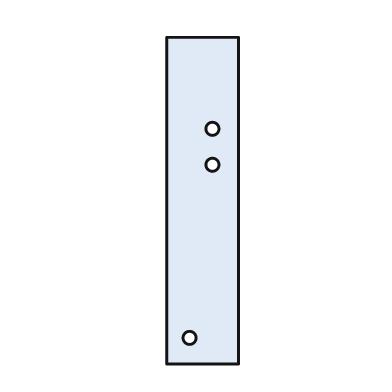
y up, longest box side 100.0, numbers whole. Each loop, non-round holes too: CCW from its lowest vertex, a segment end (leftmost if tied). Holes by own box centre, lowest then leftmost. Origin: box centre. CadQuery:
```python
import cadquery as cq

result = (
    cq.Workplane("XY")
    .moveTo(-11.0, -50.0)
    .lineTo(11.0, -50.0)
    .lineTo(11.0, 50.0)
    .lineTo(-11.0, 50.0)
    .close()
    .moveTo(-4.0, -42.0)
    .circle(2.0)
    .moveTo(3.0, 11.0)
    .circle(2.0)
    .moveTo(3.0, 22.0)
    .circle(2.0)
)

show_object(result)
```